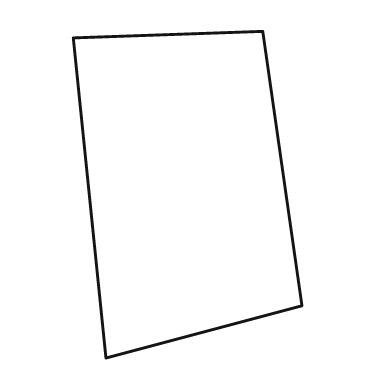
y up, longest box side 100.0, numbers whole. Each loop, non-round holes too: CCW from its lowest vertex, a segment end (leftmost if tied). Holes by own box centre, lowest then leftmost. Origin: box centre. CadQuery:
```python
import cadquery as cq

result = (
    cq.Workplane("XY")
    .moveTo(-25.0, -50.0)
    .lineTo(35.0, -34.0)
    .lineTo(23.0, 50.0)
    .lineTo(-35.0, 48.0)
    .close()
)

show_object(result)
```